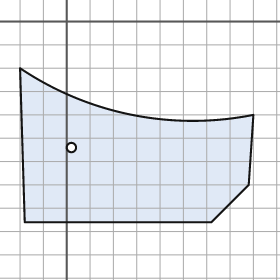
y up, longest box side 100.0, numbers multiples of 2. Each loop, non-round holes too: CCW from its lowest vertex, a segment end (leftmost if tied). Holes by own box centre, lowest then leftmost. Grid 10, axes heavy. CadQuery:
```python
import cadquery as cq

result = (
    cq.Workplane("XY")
    .moveTo(-18.0, -86.0)
    .lineTo(62.0, -86.0)
    .lineTo(78.0, -70.0)
    .lineTo(80.0, -40.0)
    .threePointArc((28.0, -40.0), (-20.0, -20.0))
    .close()
    .moveTo(2.0, -54.0)
    .circle(2.0)
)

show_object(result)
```